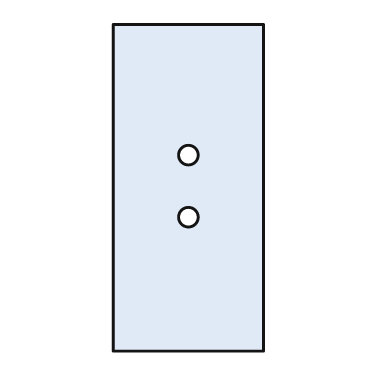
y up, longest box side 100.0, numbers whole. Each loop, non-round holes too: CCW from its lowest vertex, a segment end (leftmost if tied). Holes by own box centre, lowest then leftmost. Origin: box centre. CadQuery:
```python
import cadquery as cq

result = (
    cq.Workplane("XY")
    .moveTo(-23.0, -50.0)
    .lineTo(23.0, -50.0)
    .lineTo(23.0, 50.0)
    .lineTo(-23.0, 50.0)
    .close()
    .moveTo(0.0, -9.0)
    .circle(3.0)
    .moveTo(0.0, 10.0)
    .circle(3.0)
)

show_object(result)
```